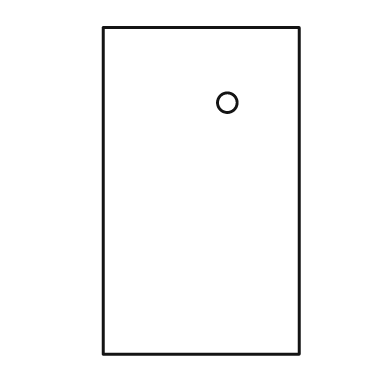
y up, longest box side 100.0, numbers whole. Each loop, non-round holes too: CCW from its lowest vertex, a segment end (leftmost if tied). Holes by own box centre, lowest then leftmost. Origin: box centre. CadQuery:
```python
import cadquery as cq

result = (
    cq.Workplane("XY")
    .moveTo(-30.0, -50.0)
    .lineTo(30.0, -50.0)
    .lineTo(30.0, 50.0)
    .lineTo(-30.0, 50.0)
    .close()
    .moveTo(8.0, 27.0)
    .circle(3.0)
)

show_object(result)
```